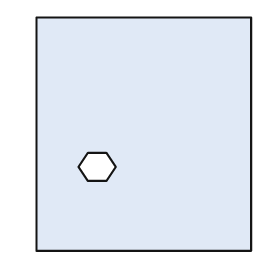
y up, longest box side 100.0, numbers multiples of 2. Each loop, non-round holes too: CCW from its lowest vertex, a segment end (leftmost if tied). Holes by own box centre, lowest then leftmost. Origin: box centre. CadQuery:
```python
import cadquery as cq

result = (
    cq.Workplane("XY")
    .moveTo(-46.0, -50.0)
    .lineTo(46.0, -50.0)
    .lineTo(46.0, 50.0)
    .lineTo(-46.0, 50.0)
    .close()
    .moveTo(-24.0, -20.0)
    .lineTo(-16.0, -20.0)
    .lineTo(-12.0, -14.0)
    .lineTo(-16.0, -8.0)
    .lineTo(-24.0, -8.0)
    .lineTo(-28.0, -14.0)
    .close()
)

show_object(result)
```